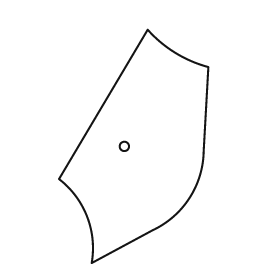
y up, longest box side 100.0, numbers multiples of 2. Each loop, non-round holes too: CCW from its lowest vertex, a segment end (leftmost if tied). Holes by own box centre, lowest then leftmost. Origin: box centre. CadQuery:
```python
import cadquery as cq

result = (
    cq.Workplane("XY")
    .moveTo(-18.0, -50.0)
    .lineTo(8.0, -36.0)
    .threePointArc((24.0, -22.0), (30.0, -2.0))
    .lineTo(32.0, 34.0)
    .threePointArc((18.0, 40.0), (6.0, 50.0))
    .lineTo(-32.0, -14.0)
    .threePointArc((-20.0, -30.0), (-18.0, -50.0))
    .close()
    .moveTo(-4.0, 0.0)
    .circle(2.0)
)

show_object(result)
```